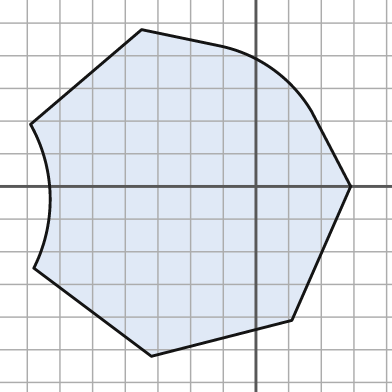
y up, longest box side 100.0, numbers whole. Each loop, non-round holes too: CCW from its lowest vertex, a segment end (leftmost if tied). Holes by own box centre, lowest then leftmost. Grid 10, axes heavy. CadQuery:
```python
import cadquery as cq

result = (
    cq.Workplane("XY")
    .moveTo(-32.0, -52.0)
    .lineTo(11.0, -41.0)
    .lineTo(29.0, 0.0)
    .lineTo(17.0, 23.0)
    .threePointArc((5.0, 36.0), (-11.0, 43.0))
    .lineTo(-35.0, 48.0)
    .lineTo(-69.0, 19.0)
    .threePointArc((-63.0, -3.0), (-68.0, -25.0))
    .close()
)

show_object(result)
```